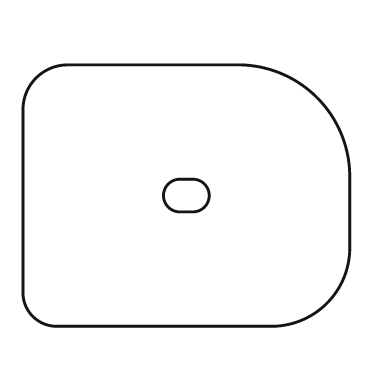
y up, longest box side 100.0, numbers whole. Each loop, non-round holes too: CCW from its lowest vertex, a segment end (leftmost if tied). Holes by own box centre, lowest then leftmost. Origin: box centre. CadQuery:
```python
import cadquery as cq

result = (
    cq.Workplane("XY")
    .moveTo(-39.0, -40.0)
    .lineTo(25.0, -40.0)
    .threePointArc((43.0, -33.0), (50.0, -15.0))
    .lineTo(50.0, 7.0)
    .threePointArc((40.0, 30.0), (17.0, 40.0))
    .lineTo(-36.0, 40.0)
    .threePointArc((-46.0, 36.0), (-50.0, 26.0))
    .lineTo(-50.0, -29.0)
    .threePointArc((-47.0, -37.0), (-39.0, -40.0))
    .close()
    .moveTo(-2.0, -5.0)
    .lineTo(2.0, -5.0)
    .threePointArc((7.0, 0.0), (2.0, 5.0))
    .lineTo(-2.0, 5.0)
    .threePointArc((-7.0, 0.0), (-2.0, -5.0))
    .close()
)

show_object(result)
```